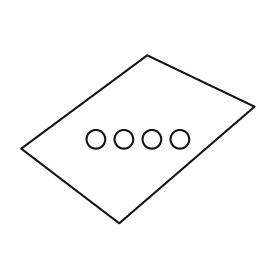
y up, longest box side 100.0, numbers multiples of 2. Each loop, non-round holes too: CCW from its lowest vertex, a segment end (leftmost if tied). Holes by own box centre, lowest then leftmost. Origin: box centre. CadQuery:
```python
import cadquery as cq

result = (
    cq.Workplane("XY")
    .moveTo(-8.0, -36.0)
    .lineTo(50.0, 14.0)
    .lineTo(4.0, 36.0)
    .lineTo(-50.0, -4.0)
    .close()
    .moveTo(-18.0, 0.0)
    .circle(4.0)
    .moveTo(-6.0, 0.0)
    .circle(4.0)
    .moveTo(6.0, 0.0)
    .circle(4.0)
    .moveTo(18.0, 0.0)
    .circle(4.0)
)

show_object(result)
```